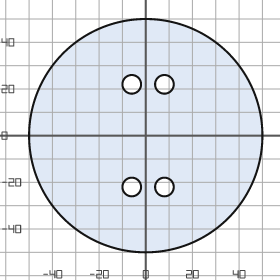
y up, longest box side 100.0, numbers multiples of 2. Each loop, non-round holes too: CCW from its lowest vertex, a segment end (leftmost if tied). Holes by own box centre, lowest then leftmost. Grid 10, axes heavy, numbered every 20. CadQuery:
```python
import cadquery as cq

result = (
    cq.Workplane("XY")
    .moveTo(0.0, 0.0)
    .circle(50.0)
    .moveTo(-6.0, -22.0)
    .circle(4.0)
    .moveTo(8.0, -22.0)
    .circle(4.0)
    .moveTo(-6.0, 22.0)
    .circle(4.0)
    .moveTo(8.0, 22.0)
    .circle(4.0)
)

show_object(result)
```